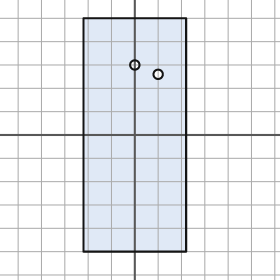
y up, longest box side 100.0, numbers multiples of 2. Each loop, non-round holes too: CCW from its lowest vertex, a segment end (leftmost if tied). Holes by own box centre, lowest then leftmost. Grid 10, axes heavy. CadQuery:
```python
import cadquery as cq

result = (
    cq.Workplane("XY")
    .moveTo(-22.0, -50.0)
    .lineTo(22.0, -50.0)
    .lineTo(22.0, 50.0)
    .lineTo(-22.0, 50.0)
    .close()
    .moveTo(10.0, 26.0)
    .circle(2.0)
    .moveTo(0.0, 30.0)
    .circle(2.0)
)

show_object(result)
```